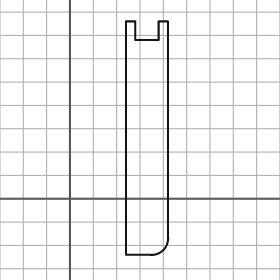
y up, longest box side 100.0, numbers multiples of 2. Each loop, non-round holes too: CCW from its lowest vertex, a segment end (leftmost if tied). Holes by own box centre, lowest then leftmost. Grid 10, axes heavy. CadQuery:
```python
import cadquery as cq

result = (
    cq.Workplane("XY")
    .moveTo(24.0, -24.0)
    .lineTo(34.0, -24.0)
    .threePointArc((40.0, -22.0), (42.0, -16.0))
    .lineTo(42.0, 76.0)
    .lineTo(38.0, 76.0)
    .lineTo(38.0, 68.0)
    .lineTo(28.0, 68.0)
    .lineTo(28.0, 76.0)
    .lineTo(24.0, 76.0)
    .close()
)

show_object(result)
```